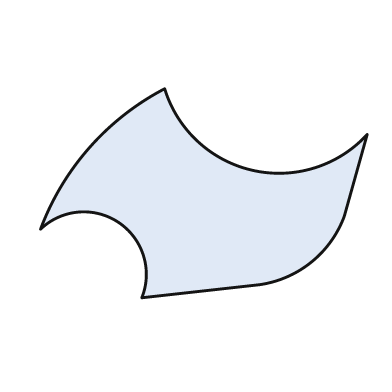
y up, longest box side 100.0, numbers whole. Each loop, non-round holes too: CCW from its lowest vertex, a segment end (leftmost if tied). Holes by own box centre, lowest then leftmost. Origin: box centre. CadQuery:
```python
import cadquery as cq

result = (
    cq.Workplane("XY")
    .moveTo(-19.0, -32.0)
    .lineTo(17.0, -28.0)
    .threePointArc((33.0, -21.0), (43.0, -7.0))
    .lineTo(50.0, 18.0)
    .threePointArc((15.0, 7.0), (-12.0, 32.0))
    .threePointArc((-35.0, 14.0), (-50.0, -11.0))
    .threePointArc((-26.0, -9.0), (-19.0, -32.0))
    .close()
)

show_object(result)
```